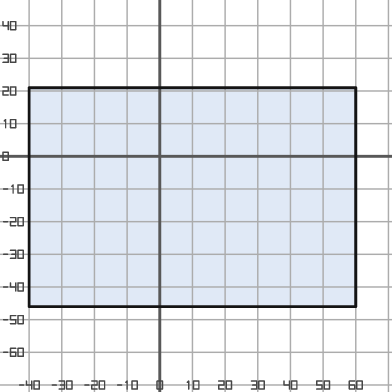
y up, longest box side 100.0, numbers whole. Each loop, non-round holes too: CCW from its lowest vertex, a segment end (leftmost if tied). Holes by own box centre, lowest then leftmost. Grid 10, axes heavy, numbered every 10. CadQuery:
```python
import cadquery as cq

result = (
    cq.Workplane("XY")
    .moveTo(-40.0, -46.0)
    .lineTo(60.0, -46.0)
    .lineTo(60.0, 21.0)
    .lineTo(-40.0, 21.0)
    .close()
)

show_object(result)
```